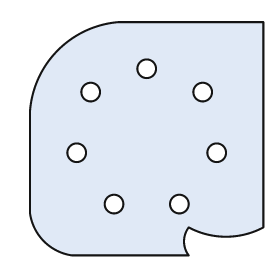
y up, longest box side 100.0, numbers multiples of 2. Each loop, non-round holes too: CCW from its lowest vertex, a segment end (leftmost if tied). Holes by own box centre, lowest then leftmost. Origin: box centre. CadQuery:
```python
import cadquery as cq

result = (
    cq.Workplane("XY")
    .moveTo(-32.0, -50.0)
    .lineTo(18.0, -50.0)
    .threePointArc((16.0, -44.0), (18.0, -38.0))
    .threePointArc((34.0, -42.0), (50.0, -38.0))
    .lineTo(50.0, 50.0)
    .lineTo(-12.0, 50.0)
    .threePointArc((-38.0, 38.0), (-50.0, 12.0))
    .lineTo(-50.0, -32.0)
    .threePointArc((-44.0, -44.0), (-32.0, -50.0))
    .close()
    .moveTo(-14.0, -28.0)
    .circle(4.0)
    .moveTo(14.0, -28.0)
    .circle(4.0)
    .moveTo(-30.0, -6.0)
    .circle(4.0)
    .moveTo(30.0, -6.0)
    .circle(4.0)
    .moveTo(-24.0, 20.0)
    .circle(4.0)
    .moveTo(24.0, 20.0)
    .circle(4.0)
    .moveTo(0.0, 30.0)
    .circle(4.0)
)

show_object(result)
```